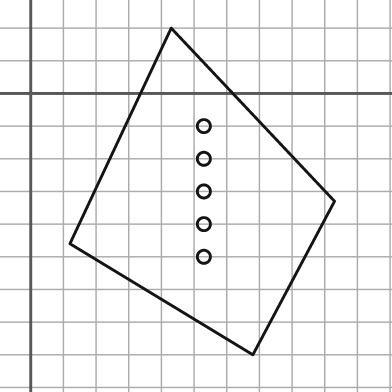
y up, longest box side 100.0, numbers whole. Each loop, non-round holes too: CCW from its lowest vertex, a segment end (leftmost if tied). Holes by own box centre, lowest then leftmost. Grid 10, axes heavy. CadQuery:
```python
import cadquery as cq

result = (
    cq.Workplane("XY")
    .moveTo(68.0, -80.0)
    .lineTo(93.0, -33.0)
    .lineTo(43.0, 20.0)
    .lineTo(12.0, -46.0)
    .close()
    .moveTo(53.0, -50.0)
    .circle(2.0)
    .moveTo(53.0, -40.0)
    .circle(2.0)
    .moveTo(53.0, -30.0)
    .circle(2.0)
    .moveTo(53.0, -20.0)
    .circle(2.0)
    .moveTo(53.0, -10.0)
    .circle(2.0)
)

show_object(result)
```